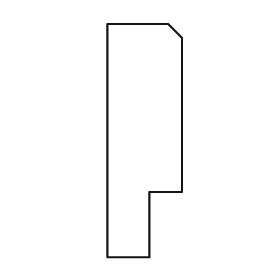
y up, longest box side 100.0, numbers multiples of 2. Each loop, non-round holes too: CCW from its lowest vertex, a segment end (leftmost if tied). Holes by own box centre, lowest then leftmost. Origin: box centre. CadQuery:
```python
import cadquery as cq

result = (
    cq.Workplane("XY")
    .moveTo(-16.0, -50.0)
    .lineTo(2.0, -50.0)
    .lineTo(2.0, -22.0)
    .lineTo(16.0, -22.0)
    .lineTo(16.0, 44.0)
    .lineTo(10.0, 50.0)
    .lineTo(-16.0, 50.0)
    .close()
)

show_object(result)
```